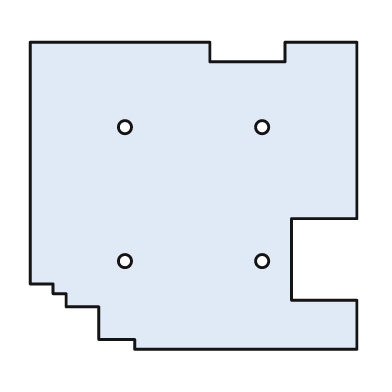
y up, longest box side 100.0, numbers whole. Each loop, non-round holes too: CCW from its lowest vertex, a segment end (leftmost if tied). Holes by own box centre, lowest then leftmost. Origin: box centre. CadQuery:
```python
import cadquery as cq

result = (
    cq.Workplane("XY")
    .moveTo(-18.0, -47.0)
    .lineTo(50.0, -47.0)
    .lineTo(50.0, -32.0)
    .lineTo(30.0, -32.0)
    .lineTo(30.0, -7.0)
    .lineTo(50.0, -7.0)
    .lineTo(50.0, 47.0)
    .lineTo(28.0, 47.0)
    .lineTo(28.0, 41.0)
    .lineTo(5.0, 41.0)
    .lineTo(5.0, 47.0)
    .lineTo(-50.0, 47.0)
    .lineTo(-50.0, -27.0)
    .lineTo(-43.0, -27.0)
    .lineTo(-43.0, -30.0)
    .lineTo(-39.0, -30.0)
    .lineTo(-39.0, -34.0)
    .lineTo(-29.0, -34.0)
    .lineTo(-29.0, -44.0)
    .lineTo(-18.0, -44.0)
    .close()
    .moveTo(-21.0, -20.0)
    .circle(2.0)
    .moveTo(21.0, -20.0)
    .circle(2.0)
    .moveTo(-21.0, 21.0)
    .circle(2.0)
    .moveTo(21.0, 21.0)
    .circle(2.0)
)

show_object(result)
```